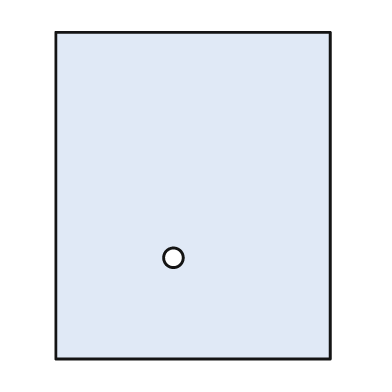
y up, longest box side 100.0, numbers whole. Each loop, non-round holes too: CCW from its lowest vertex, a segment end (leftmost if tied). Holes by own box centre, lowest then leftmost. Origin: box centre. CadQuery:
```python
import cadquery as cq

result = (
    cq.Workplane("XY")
    .moveTo(-42.0, -50.0)
    .lineTo(42.0, -50.0)
    .lineTo(42.0, 50.0)
    .lineTo(-42.0, 50.0)
    .close()
    .moveTo(-6.0, -19.0)
    .circle(3.0)
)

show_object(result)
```